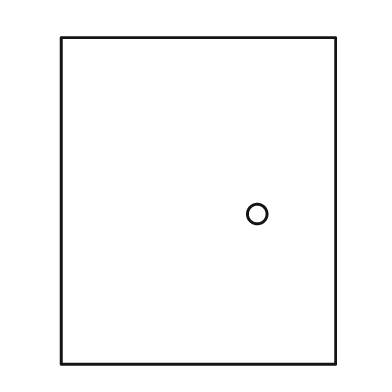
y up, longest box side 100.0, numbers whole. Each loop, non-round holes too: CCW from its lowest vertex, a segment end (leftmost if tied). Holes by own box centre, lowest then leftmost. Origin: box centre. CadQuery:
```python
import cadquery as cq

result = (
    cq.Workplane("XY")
    .moveTo(-42.0, -50.0)
    .lineTo(42.0, -50.0)
    .lineTo(42.0, 50.0)
    .lineTo(-42.0, 50.0)
    .close()
    .moveTo(18.0, -4.0)
    .circle(3.0)
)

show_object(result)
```